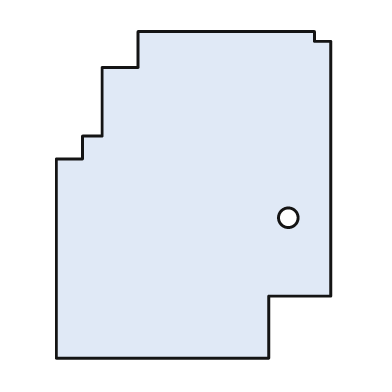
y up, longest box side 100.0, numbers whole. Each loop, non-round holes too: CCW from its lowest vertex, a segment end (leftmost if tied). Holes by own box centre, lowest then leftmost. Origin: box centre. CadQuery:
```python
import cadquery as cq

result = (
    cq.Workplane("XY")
    .moveTo(-42.0, -50.0)
    .lineTo(23.0, -50.0)
    .lineTo(23.0, -31.0)
    .lineTo(42.0, -31.0)
    .lineTo(42.0, 47.0)
    .lineTo(37.0, 47.0)
    .lineTo(37.0, 50.0)
    .lineTo(-17.0, 50.0)
    .lineTo(-17.0, 39.0)
    .lineTo(-28.0, 39.0)
    .lineTo(-28.0, 18.0)
    .lineTo(-34.0, 18.0)
    .lineTo(-34.0, 11.0)
    .lineTo(-42.0, 11.0)
    .close()
    .moveTo(29.0, -7.0)
    .circle(3.0)
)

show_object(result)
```